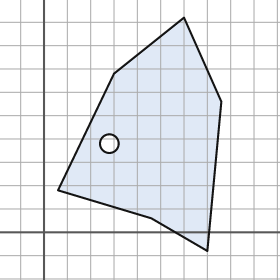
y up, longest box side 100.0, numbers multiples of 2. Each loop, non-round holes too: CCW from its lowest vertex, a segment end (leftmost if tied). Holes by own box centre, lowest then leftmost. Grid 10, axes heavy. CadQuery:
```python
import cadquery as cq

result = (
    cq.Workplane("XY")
    .moveTo(70.0, -8.0)
    .lineTo(76.0, 56.0)
    .lineTo(60.0, 92.0)
    .lineTo(30.0, 68.0)
    .lineTo(6.0, 18.0)
    .lineTo(46.0, 6.0)
    .close()
    .moveTo(28.0, 38.0)
    .circle(4.0)
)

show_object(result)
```